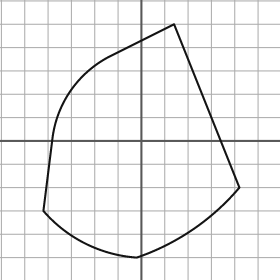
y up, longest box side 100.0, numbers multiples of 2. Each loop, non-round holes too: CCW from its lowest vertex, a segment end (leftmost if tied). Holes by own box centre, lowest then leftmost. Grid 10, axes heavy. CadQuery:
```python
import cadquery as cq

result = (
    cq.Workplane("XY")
    .moveTo(-2.0, -50.0)
    .threePointArc((22.0, -38.0), (42.0, -20.0))
    .lineTo(14.0, 50.0)
    .lineTo(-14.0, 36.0)
    .threePointArc((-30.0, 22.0), (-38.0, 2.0))
    .lineTo(-42.0, -30.0)
    .threePointArc((-24.0, -44.0), (-2.0, -50.0))
    .close()
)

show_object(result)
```